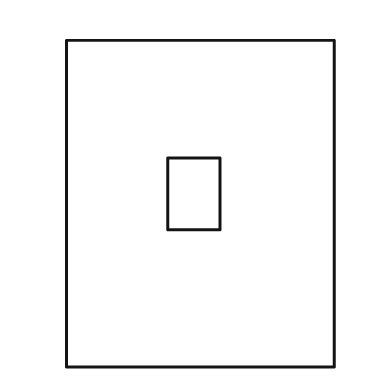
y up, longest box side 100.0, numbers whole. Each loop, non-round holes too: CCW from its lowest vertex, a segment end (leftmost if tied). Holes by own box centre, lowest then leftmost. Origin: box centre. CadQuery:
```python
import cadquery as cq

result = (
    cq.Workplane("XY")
    .moveTo(-41.0, -50.0)
    .lineTo(41.0, -50.0)
    .lineTo(41.0, 50.0)
    .lineTo(-41.0, 50.0)
    .close()
    .moveTo(-10.0, -8.0)
    .lineTo(6.0, -8.0)
    .lineTo(6.0, 14.0)
    .lineTo(-10.0, 14.0)
    .close()
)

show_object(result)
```